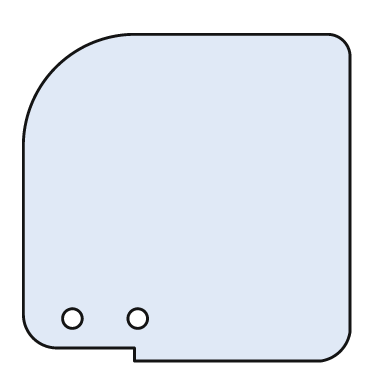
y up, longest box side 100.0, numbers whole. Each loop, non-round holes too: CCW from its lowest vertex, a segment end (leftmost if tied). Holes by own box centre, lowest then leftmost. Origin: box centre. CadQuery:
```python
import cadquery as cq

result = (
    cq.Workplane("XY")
    .moveTo(-16.0, -50.0)
    .lineTo(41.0, -50.0)
    .threePointArc((47.0, -47.0), (50.0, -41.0))
    .lineTo(50.0, 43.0)
    .threePointArc((48.0, 48.0), (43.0, 50.0))
    .lineTo(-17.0, 50.0)
    .threePointArc((-40.0, 40.0), (-50.0, 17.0))
    .lineTo(-50.0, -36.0)
    .threePointArc((-47.0, -43.0), (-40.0, -46.0))
    .lineTo(-16.0, -46.0)
    .close()
    .moveTo(-35.0, -37.0)
    .circle(3.0)
    .moveTo(-15.0, -37.0)
    .circle(3.0)
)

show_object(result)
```